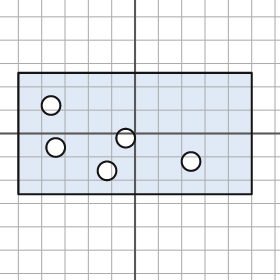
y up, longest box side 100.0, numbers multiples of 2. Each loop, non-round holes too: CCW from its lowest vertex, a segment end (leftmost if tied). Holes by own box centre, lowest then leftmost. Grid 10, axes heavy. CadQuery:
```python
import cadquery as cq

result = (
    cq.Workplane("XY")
    .moveTo(-50.0, -26.0)
    .lineTo(50.0, -26.0)
    .lineTo(50.0, 26.0)
    .lineTo(-50.0, 26.0)
    .close()
    .moveTo(-12.0, -16.0)
    .circle(4.0)
    .moveTo(24.0, -12.0)
    .circle(4.0)
    .moveTo(-34.0, -6.0)
    .circle(4.0)
    .moveTo(-4.0, -2.0)
    .circle(4.0)
    .moveTo(-36.0, 12.0)
    .circle(4.0)
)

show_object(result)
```